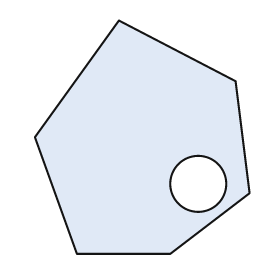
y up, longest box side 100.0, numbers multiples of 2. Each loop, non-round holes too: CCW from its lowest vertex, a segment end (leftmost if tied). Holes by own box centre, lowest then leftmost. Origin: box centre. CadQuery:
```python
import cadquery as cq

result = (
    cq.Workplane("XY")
    .moveTo(-28.0, -50.0)
    .lineTo(12.0, -50.0)
    .lineTo(46.0, -24.0)
    .lineTo(40.0, 24.0)
    .lineTo(-10.0, 50.0)
    .lineTo(-46.0, 0.0)
    .close()
    .moveTo(24.0, -20.0)
    .circle(12.0)
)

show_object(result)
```